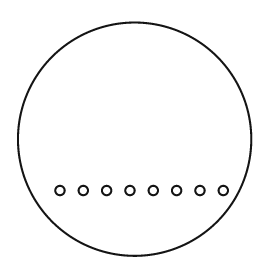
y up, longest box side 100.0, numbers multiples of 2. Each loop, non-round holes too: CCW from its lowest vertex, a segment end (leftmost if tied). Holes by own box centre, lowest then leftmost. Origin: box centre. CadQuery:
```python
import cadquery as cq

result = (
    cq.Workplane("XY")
    .moveTo(0.0, 0.0)
    .circle(50.0)
    .moveTo(-32.0, -22.0)
    .circle(2.0)
    .moveTo(-22.0, -22.0)
    .circle(2.0)
    .moveTo(-12.0, -22.0)
    .circle(2.0)
    .moveTo(-2.0, -22.0)
    .circle(2.0)
    .moveTo(8.0, -22.0)
    .circle(2.0)
    .moveTo(18.0, -22.0)
    .circle(2.0)
    .moveTo(28.0, -22.0)
    .circle(2.0)
    .moveTo(38.0, -22.0)
    .circle(2.0)
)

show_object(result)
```